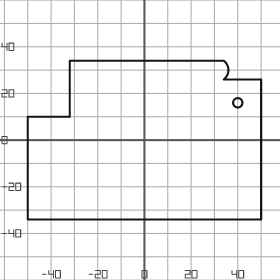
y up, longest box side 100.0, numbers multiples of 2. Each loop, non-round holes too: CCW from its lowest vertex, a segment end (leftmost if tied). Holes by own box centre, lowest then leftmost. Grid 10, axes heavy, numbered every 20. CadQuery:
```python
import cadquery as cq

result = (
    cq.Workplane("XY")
    .moveTo(-50.0, -34.0)
    .lineTo(50.0, -34.0)
    .lineTo(50.0, 26.0)
    .lineTo(34.0, 26.0)
    .threePointArc((36.0, 30.0), (34.0, 34.0))
    .lineTo(-32.0, 34.0)
    .lineTo(-32.0, 10.0)
    .lineTo(-50.0, 10.0)
    .close()
    .moveTo(40.0, 16.0)
    .circle(2.0)
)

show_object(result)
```